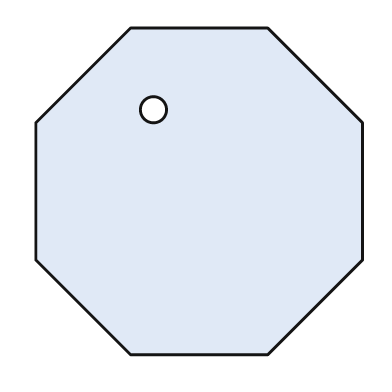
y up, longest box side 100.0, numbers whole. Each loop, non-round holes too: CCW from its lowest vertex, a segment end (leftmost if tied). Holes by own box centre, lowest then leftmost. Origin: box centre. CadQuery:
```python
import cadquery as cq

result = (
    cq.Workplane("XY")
    .moveTo(-21.0, -50.0)
    .lineTo(21.0, -50.0)
    .lineTo(50.0, -21.0)
    .lineTo(50.0, 21.0)
    .lineTo(21.0, 50.0)
    .lineTo(-21.0, 50.0)
    .lineTo(-50.0, 21.0)
    .lineTo(-50.0, -21.0)
    .close()
    .moveTo(-14.0, 25.0)
    .circle(4.0)
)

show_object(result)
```